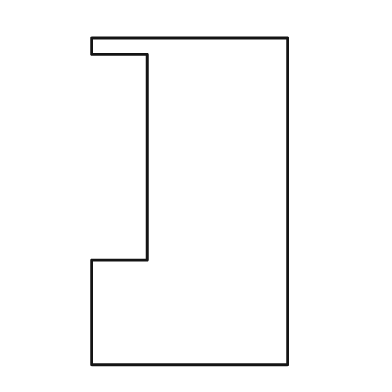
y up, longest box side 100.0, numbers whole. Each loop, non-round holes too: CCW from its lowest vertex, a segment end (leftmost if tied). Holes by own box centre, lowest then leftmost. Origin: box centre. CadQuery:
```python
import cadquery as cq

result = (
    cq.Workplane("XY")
    .moveTo(-30.0, -50.0)
    .lineTo(30.0, -50.0)
    .lineTo(30.0, 50.0)
    .lineTo(-30.0, 50.0)
    .lineTo(-30.0, 45.0)
    .lineTo(-13.0, 45.0)
    .lineTo(-13.0, -18.0)
    .lineTo(-30.0, -18.0)
    .close()
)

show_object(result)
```